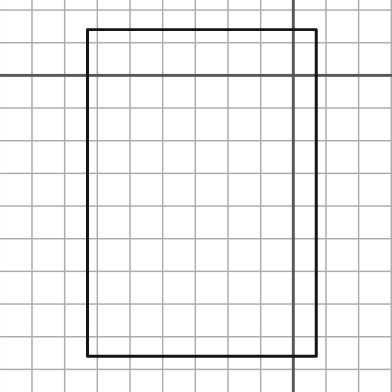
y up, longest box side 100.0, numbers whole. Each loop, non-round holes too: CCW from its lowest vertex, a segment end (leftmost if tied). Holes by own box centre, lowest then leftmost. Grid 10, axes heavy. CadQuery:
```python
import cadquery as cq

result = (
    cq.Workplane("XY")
    .moveTo(-63.0, -86.0)
    .lineTo(7.0, -86.0)
    .lineTo(7.0, 14.0)
    .lineTo(-63.0, 14.0)
    .close()
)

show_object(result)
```